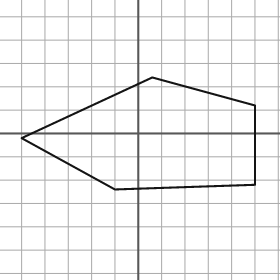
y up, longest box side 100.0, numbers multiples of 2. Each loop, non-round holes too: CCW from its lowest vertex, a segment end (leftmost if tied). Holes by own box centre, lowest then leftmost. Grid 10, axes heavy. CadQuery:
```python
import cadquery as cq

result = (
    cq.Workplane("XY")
    .moveTo(-10.0, -24.0)
    .lineTo(50.0, -22.0)
    .lineTo(50.0, 12.0)
    .lineTo(6.0, 24.0)
    .lineTo(-50.0, -2.0)
    .close()
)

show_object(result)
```